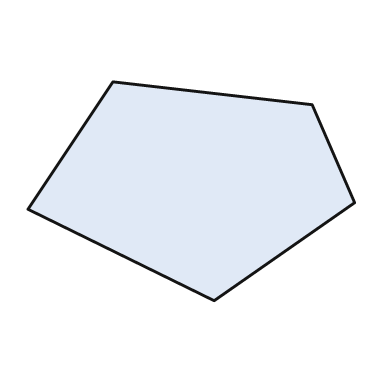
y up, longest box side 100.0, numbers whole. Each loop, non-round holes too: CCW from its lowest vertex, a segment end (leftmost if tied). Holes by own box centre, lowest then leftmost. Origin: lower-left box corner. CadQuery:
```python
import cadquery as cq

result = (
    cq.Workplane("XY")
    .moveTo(57.0, 0.0)
    .lineTo(100.0, 30.0)
    .lineTo(87.0, 60.0)
    .lineTo(26.0, 67.0)
    .lineTo(0.0, 28.0)
    .close()
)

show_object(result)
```